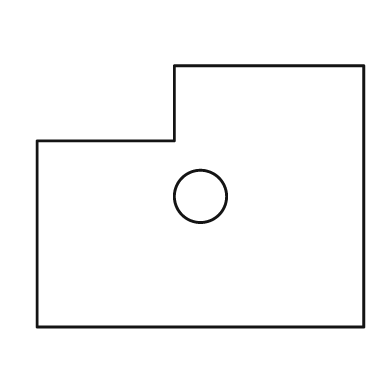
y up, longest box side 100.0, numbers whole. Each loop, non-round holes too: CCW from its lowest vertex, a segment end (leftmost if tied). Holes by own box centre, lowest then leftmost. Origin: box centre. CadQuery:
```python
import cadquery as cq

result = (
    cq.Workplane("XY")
    .moveTo(-50.0, -40.0)
    .lineTo(50.0, -40.0)
    .lineTo(50.0, 40.0)
    .lineTo(-8.0, 40.0)
    .lineTo(-8.0, 17.0)
    .lineTo(-50.0, 17.0)
    .close()
    .moveTo(0.0, 0.0)
    .circle(8.0)
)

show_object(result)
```